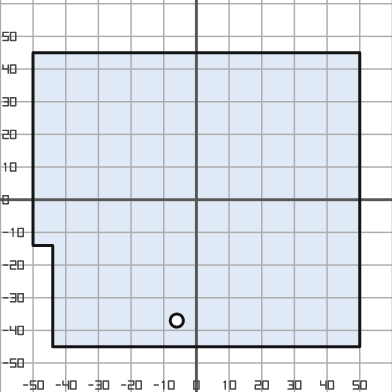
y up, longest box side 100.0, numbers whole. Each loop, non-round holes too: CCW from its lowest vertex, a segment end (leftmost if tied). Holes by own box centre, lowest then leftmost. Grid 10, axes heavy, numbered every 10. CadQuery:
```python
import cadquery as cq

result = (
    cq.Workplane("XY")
    .moveTo(-44.0, -45.0)
    .lineTo(50.0, -45.0)
    .lineTo(50.0, 45.0)
    .lineTo(-50.0, 45.0)
    .lineTo(-50.0, -14.0)
    .lineTo(-44.0, -14.0)
    .close()
    .moveTo(-6.0, -37.0)
    .circle(2.0)
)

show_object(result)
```